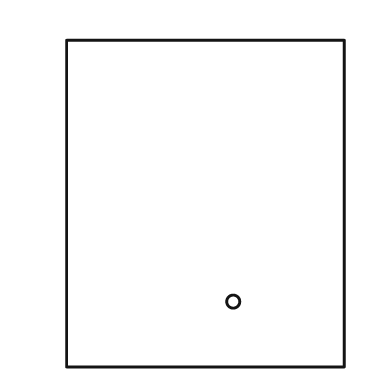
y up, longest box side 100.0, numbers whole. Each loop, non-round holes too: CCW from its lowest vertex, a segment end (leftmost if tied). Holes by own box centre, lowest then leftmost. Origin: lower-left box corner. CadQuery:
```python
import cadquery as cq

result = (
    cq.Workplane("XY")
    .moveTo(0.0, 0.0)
    .lineTo(85.0, 0.0)
    .lineTo(85.0, 100.0)
    .lineTo(0.0, 100.0)
    .close()
    .moveTo(51.0, 20.0)
    .circle(2.0)
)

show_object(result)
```